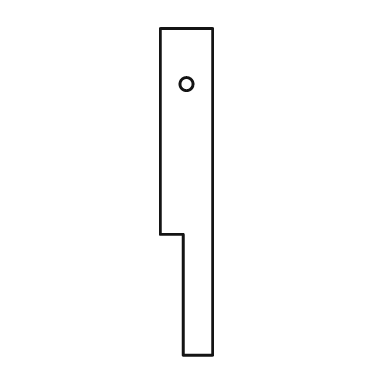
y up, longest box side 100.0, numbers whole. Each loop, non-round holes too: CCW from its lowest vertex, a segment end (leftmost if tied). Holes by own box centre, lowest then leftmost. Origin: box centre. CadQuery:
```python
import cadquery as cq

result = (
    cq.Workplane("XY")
    .moveTo(-1.0, -50.0)
    .lineTo(8.0, -50.0)
    .lineTo(8.0, 50.0)
    .lineTo(-8.0, 50.0)
    .lineTo(-8.0, -13.0)
    .lineTo(-1.0, -13.0)
    .close()
    .moveTo(0.0, 33.0)
    .circle(2.0)
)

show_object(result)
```